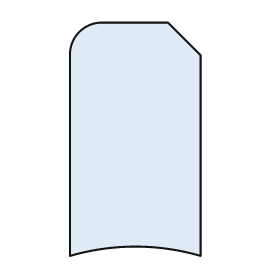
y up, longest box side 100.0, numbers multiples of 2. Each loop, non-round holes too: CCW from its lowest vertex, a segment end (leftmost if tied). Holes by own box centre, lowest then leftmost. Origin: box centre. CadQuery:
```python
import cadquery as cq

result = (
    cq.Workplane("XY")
    .moveTo(-28.0, -50.0)
    .threePointArc((0.0, -46.0), (28.0, -50.0))
    .lineTo(28.0, 36.0)
    .lineTo(14.0, 50.0)
    .lineTo(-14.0, 50.0)
    .threePointArc((-24.0, 46.0), (-28.0, 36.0))
    .close()
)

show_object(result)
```